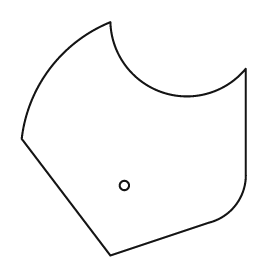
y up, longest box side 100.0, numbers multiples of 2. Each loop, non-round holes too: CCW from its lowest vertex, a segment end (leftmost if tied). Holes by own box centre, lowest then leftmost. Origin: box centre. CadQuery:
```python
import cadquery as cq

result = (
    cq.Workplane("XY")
    .moveTo(-10.0, -50.0)
    .lineTo(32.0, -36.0)
    .threePointArc((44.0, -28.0), (48.0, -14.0))
    .lineTo(48.0, 30.0)
    .threePointArc((12.0, 20.0), (-10.0, 50.0))
    .threePointArc((-36.0, 30.0), (-48.0, 0.0))
    .close()
    .moveTo(-4.0, -20.0)
    .circle(2.0)
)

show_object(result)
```